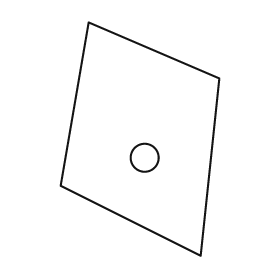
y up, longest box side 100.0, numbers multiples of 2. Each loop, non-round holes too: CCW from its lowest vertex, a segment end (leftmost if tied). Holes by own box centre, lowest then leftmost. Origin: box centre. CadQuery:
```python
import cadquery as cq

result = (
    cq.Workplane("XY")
    .moveTo(26.0, -50.0)
    .lineTo(34.0, 26.0)
    .lineTo(-22.0, 50.0)
    .lineTo(-34.0, -20.0)
    .close()
    .moveTo(2.0, -8.0)
    .circle(6.0)
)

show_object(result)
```